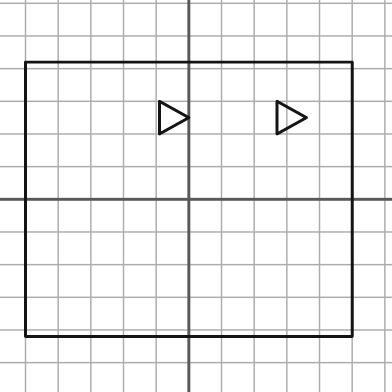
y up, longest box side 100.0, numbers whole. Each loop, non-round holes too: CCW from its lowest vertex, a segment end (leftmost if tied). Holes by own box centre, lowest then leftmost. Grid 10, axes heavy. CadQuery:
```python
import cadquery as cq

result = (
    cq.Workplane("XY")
    .moveTo(-50.0, -42.0)
    .lineTo(50.0, -42.0)
    .lineTo(50.0, 42.0)
    .lineTo(-50.0, 42.0)
    .close()
    .moveTo(-9.0, 20.0)
    .lineTo(0.0, 25.0)
    .lineTo(-9.0, 30.0)
    .close()
    .moveTo(27.0, 20.0)
    .lineTo(36.0, 25.0)
    .lineTo(27.0, 30.0)
    .close()
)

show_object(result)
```